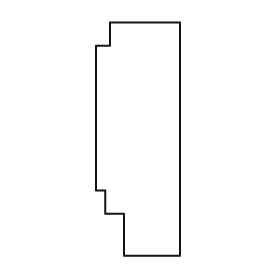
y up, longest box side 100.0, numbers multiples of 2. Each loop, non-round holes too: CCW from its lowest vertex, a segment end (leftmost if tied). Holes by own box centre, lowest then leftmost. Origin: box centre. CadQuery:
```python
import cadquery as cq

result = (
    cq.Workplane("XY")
    .moveTo(-6.0, -50.0)
    .lineTo(18.0, -50.0)
    .lineTo(18.0, 50.0)
    .lineTo(-12.0, 50.0)
    .lineTo(-12.0, 40.0)
    .lineTo(-18.0, 40.0)
    .lineTo(-18.0, -22.0)
    .lineTo(-14.0, -22.0)
    .lineTo(-14.0, -32.0)
    .lineTo(-6.0, -32.0)
    .close()
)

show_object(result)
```